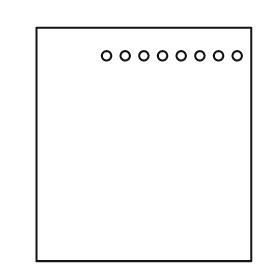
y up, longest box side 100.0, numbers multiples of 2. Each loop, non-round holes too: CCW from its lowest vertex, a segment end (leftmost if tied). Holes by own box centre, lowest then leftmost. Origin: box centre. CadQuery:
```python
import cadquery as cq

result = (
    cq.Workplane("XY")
    .moveTo(-46.0, -50.0)
    .lineTo(46.0, -50.0)
    .lineTo(46.0, 50.0)
    .lineTo(-46.0, 50.0)
    .close()
    .moveTo(-16.0, 38.0)
    .circle(2.0)
    .moveTo(-8.0, 38.0)
    .circle(2.0)
    .moveTo(0.0, 38.0)
    .circle(2.0)
    .moveTo(8.0, 38.0)
    .circle(2.0)
    .moveTo(16.0, 38.0)
    .circle(2.0)
    .moveTo(24.0, 38.0)
    .circle(2.0)
    .moveTo(32.0, 38.0)
    .circle(2.0)
    .moveTo(40.0, 38.0)
    .circle(2.0)
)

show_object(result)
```